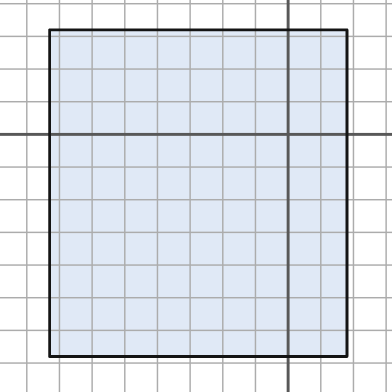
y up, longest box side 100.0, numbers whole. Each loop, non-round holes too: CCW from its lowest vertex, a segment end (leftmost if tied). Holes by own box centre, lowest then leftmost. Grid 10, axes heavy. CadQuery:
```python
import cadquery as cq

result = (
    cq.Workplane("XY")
    .moveTo(-73.0, -68.0)
    .lineTo(18.0, -68.0)
    .lineTo(18.0, 32.0)
    .lineTo(-73.0, 32.0)
    .close()
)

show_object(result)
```